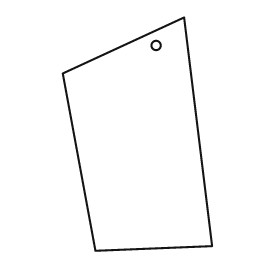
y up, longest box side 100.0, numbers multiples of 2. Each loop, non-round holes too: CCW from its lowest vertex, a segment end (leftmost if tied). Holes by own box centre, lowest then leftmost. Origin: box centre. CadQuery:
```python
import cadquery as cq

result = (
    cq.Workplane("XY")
    .moveTo(-18.0, -50.0)
    .lineTo(32.0, -48.0)
    .lineTo(20.0, 50.0)
    .lineTo(-32.0, 26.0)
    .close()
    .moveTo(8.0, 38.0)
    .circle(2.0)
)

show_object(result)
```